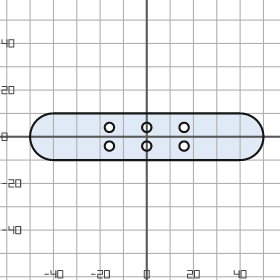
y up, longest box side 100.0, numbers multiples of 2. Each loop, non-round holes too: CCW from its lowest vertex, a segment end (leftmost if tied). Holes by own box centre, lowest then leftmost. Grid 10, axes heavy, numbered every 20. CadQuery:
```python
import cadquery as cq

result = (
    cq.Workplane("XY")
    .moveTo(-40.0, -10.0)
    .lineTo(40.0, -10.0)
    .threePointArc((50.0, 0.0), (40.0, 10.0))
    .lineTo(-40.0, 10.0)
    .threePointArc((-50.0, 0.0), (-40.0, -10.0))
    .close()
    .moveTo(-16.0, -4.0)
    .circle(2.0)
    .moveTo(0.0, -4.0)
    .circle(2.0)
    .moveTo(16.0, -4.0)
    .circle(2.0)
    .moveTo(-16.0, 4.0)
    .circle(2.0)
    .moveTo(0.0, 4.0)
    .circle(2.0)
    .moveTo(16.0, 4.0)
    .circle(2.0)
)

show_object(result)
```